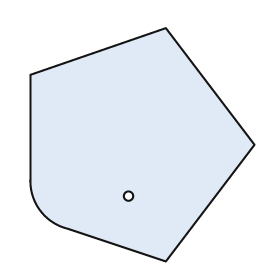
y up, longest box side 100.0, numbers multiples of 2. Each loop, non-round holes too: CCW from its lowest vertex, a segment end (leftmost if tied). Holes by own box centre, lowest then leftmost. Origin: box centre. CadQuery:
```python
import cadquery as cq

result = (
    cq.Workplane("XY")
    .moveTo(10.0, -50.0)
    .lineTo(48.0, 0.0)
    .lineTo(10.0, 50.0)
    .lineTo(-48.0, 30.0)
    .lineTo(-48.0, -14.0)
    .threePointArc((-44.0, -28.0), (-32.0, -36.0))
    .close()
    .moveTo(-6.0, -22.0)
    .circle(2.0)
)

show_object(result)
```